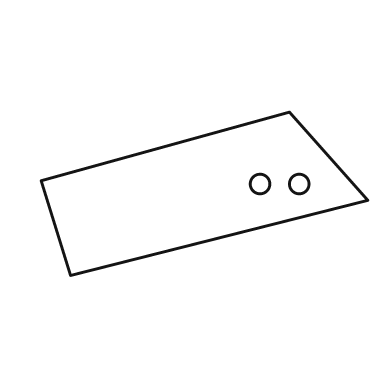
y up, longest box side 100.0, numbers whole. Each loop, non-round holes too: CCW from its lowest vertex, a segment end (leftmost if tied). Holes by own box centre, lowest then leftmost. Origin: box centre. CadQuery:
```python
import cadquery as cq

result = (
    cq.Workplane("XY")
    .moveTo(-41.0, -25.0)
    .lineTo(50.0, -2.0)
    .lineTo(26.0, 25.0)
    .lineTo(-50.0, 4.0)
    .close()
    .moveTo(17.0, 3.0)
    .circle(3.0)
    .moveTo(29.0, 3.0)
    .circle(3.0)
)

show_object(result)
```